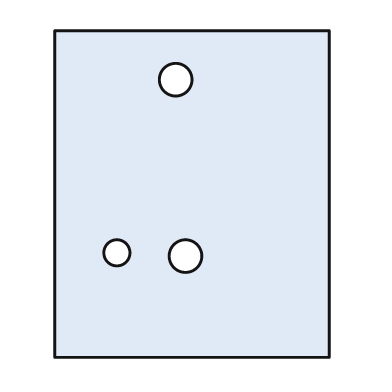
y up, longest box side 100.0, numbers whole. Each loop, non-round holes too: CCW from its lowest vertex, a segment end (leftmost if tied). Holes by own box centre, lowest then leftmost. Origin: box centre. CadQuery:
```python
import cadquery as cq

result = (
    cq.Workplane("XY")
    .moveTo(-42.0, -50.0)
    .lineTo(42.0, -50.0)
    .lineTo(42.0, 50.0)
    .lineTo(-42.0, 50.0)
    .close()
    .moveTo(-2.0, -19.0)
    .circle(5.0)
    .moveTo(-23.0, -18.0)
    .circle(4.0)
    .moveTo(-5.0, 35.0)
    .circle(5.0)
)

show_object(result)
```